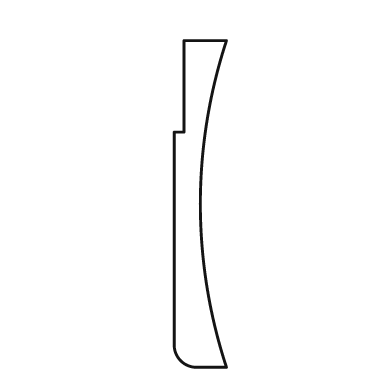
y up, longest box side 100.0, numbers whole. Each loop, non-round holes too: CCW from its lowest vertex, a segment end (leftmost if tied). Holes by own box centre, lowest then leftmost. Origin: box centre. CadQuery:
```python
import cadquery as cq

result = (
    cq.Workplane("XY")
    .moveTo(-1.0, -50.0)
    .lineTo(8.0, -50.0)
    .threePointArc((0.0, 0.0), (8.0, 50.0))
    .lineTo(-5.0, 50.0)
    .lineTo(-5.0, 22.0)
    .lineTo(-8.0, 22.0)
    .lineTo(-8.0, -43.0)
    .threePointArc((-6.0, -48.0), (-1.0, -50.0))
    .close()
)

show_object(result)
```